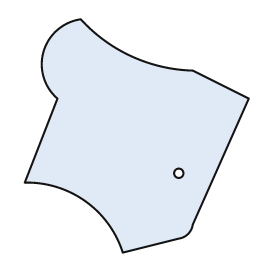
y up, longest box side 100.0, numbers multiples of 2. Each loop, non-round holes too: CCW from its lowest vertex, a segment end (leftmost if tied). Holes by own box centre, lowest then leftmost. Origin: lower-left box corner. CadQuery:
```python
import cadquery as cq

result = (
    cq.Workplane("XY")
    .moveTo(42.0, 0.0)
    .lineTo(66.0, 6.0)
    .threePointArc((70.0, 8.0), (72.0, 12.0))
    .lineTo(96.0, 66.0)
    .lineTo(72.0, 78.0)
    .threePointArc((46.0, 84.0), (24.0, 100.0))
    .threePointArc((8.0, 86.0), (14.0, 66.0))
    .lineTo(0.0, 30.0)
    .threePointArc((26.0, 22.0), (42.0, 0.0))
    .close()
    .moveTo(66.0, 34.0)
    .circle(2.0)
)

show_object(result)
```